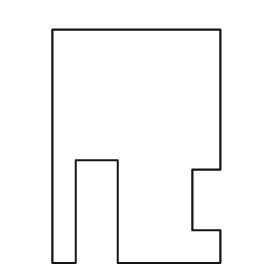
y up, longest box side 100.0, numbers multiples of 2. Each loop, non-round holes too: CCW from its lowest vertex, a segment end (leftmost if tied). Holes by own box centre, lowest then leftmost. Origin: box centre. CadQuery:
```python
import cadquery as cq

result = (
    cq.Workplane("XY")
    .moveTo(-36.0, -50.0)
    .lineTo(-26.0, -50.0)
    .lineTo(-26.0, -6.0)
    .lineTo(-8.0, -6.0)
    .lineTo(-8.0, -50.0)
    .lineTo(36.0, -50.0)
    .lineTo(36.0, -36.0)
    .lineTo(24.0, -36.0)
    .lineTo(24.0, -10.0)
    .lineTo(36.0, -10.0)
    .lineTo(36.0, 50.0)
    .lineTo(-36.0, 50.0)
    .close()
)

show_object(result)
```